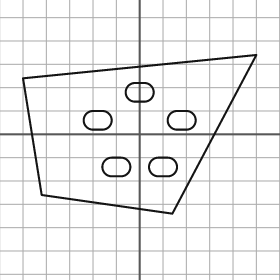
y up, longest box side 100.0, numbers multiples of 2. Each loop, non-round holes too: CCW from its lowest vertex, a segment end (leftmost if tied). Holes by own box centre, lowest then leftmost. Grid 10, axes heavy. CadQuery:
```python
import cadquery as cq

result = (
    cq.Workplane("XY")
    .moveTo(14.0, -34.0)
    .lineTo(50.0, 34.0)
    .lineTo(-50.0, 24.0)
    .lineTo(-42.0, -26.0)
    .close()
    .moveTo(-12.0, -18.0)
    .lineTo(-8.0, -18.0)
    .threePointArc((-4.0, -14.0), (-8.0, -10.0))
    .lineTo(-12.0, -10.0)
    .threePointArc((-16.0, -14.0), (-12.0, -18.0))
    .close()
    .moveTo(8.0, -18.0)
    .lineTo(12.0, -18.0)
    .threePointArc((16.0, -14.0), (12.0, -10.0))
    .lineTo(8.0, -10.0)
    .threePointArc((4.0, -14.0), (8.0, -18.0))
    .close()
    .moveTo(-20.0, 2.0)
    .lineTo(-16.0, 2.0)
    .threePointArc((-12.0, 6.0), (-16.0, 10.0))
    .lineTo(-20.0, 10.0)
    .threePointArc((-24.0, 6.0), (-20.0, 2.0))
    .close()
    .moveTo(16.0, 2.0)
    .lineTo(20.0, 2.0)
    .threePointArc((24.0, 6.0), (20.0, 10.0))
    .lineTo(16.0, 10.0)
    .threePointArc((12.0, 6.0), (16.0, 2.0))
    .close()
    .moveTo(-2.0, 14.0)
    .lineTo(2.0, 14.0)
    .threePointArc((6.0, 18.0), (2.0, 22.0))
    .lineTo(-2.0, 22.0)
    .threePointArc((-6.0, 18.0), (-2.0, 14.0))
    .close()
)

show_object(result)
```